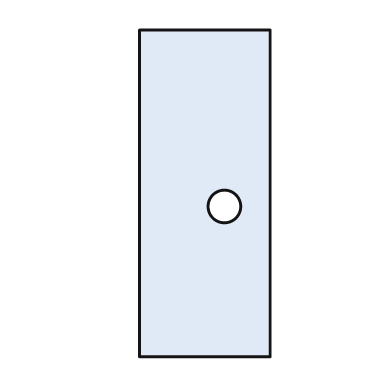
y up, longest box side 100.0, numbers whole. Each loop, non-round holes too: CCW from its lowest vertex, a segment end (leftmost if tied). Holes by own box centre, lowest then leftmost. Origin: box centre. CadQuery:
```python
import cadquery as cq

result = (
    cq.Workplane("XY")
    .moveTo(-20.0, -50.0)
    .lineTo(20.0, -50.0)
    .lineTo(20.0, 50.0)
    .lineTo(-20.0, 50.0)
    .close()
    .moveTo(6.0, -4.0)
    .circle(5.0)
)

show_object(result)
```